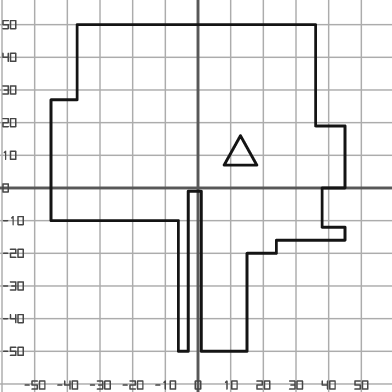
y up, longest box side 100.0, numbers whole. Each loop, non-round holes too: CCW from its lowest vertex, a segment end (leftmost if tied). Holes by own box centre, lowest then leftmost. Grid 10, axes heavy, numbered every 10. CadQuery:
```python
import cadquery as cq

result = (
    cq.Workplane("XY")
    .moveTo(-6.0, -50.0)
    .lineTo(-3.0, -50.0)
    .lineTo(-3.0, -1.0)
    .lineTo(1.0, -1.0)
    .lineTo(1.0, -50.0)
    .lineTo(15.0, -50.0)
    .lineTo(15.0, -20.0)
    .lineTo(24.0, -20.0)
    .lineTo(24.0, -16.0)
    .lineTo(45.0, -16.0)
    .lineTo(45.0, -12.0)
    .lineTo(38.0, -12.0)
    .lineTo(38.0, 0.0)
    .lineTo(45.0, 0.0)
    .lineTo(45.0, 19.0)
    .lineTo(36.0, 19.0)
    .lineTo(36.0, 50.0)
    .lineTo(-37.0, 50.0)
    .lineTo(-37.0, 27.0)
    .lineTo(-45.0, 27.0)
    .lineTo(-45.0, -10.0)
    .lineTo(-6.0, -10.0)
    .close()
    .moveTo(8.0, 7.0)
    .lineTo(18.0, 7.0)
    .lineTo(13.0, 16.0)
    .close()
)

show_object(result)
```